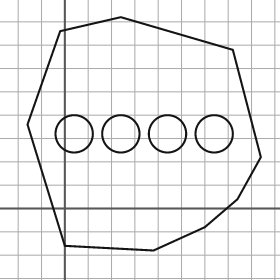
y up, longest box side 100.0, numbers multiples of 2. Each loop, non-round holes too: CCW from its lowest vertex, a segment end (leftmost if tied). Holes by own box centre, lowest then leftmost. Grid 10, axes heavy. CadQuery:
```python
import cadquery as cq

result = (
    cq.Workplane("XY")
    .moveTo(38.0, -18.0)
    .lineTo(60.0, -8.0)
    .lineTo(74.0, 4.0)
    .lineTo(84.0, 22.0)
    .lineTo(72.0, 68.0)
    .lineTo(24.0, 82.0)
    .lineTo(-2.0, 76.0)
    .lineTo(-16.0, 36.0)
    .lineTo(0.0, -16.0)
    .close()
    .moveTo(4.0, 32.0)
    .circle(8.0)
    .moveTo(24.0, 32.0)
    .circle(8.0)
    .moveTo(44.0, 32.0)
    .circle(8.0)
    .moveTo(64.0, 32.0)
    .circle(8.0)
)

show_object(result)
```